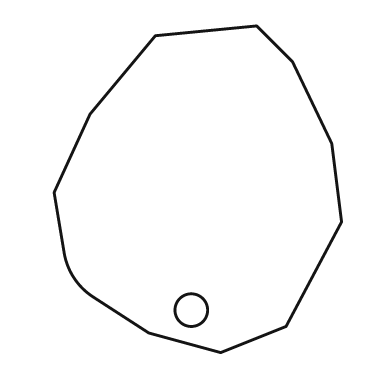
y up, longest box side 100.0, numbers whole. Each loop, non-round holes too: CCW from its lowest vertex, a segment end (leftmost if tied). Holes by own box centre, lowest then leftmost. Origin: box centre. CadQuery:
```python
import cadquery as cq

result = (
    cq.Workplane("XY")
    .moveTo(7.0, -50.0)
    .lineTo(27.0, -42.0)
    .lineTo(44.0, -10.0)
    .lineTo(41.0, 14.0)
    .lineTo(29.0, 39.0)
    .lineTo(18.0, 50.0)
    .lineTo(-13.0, 47.0)
    .lineTo(-33.0, 23.0)
    .lineTo(-44.0, -1.0)
    .lineTo(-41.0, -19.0)
    .threePointArc((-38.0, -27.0), (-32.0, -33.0))
    .lineTo(-15.0, -44.0)
    .close()
    .moveTo(-2.0, -37.0)
    .circle(5.0)
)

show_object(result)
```